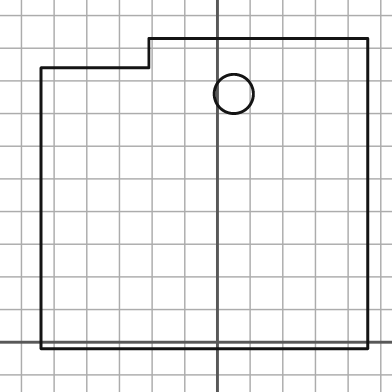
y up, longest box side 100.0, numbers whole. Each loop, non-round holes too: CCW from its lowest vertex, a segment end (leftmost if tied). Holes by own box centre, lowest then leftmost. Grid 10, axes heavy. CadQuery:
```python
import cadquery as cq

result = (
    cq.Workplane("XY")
    .moveTo(-54.0, -2.0)
    .lineTo(46.0, -2.0)
    .lineTo(46.0, 93.0)
    .lineTo(-21.0, 93.0)
    .lineTo(-21.0, 84.0)
    .lineTo(-54.0, 84.0)
    .close()
    .moveTo(5.0, 76.0)
    .circle(6.0)
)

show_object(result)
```